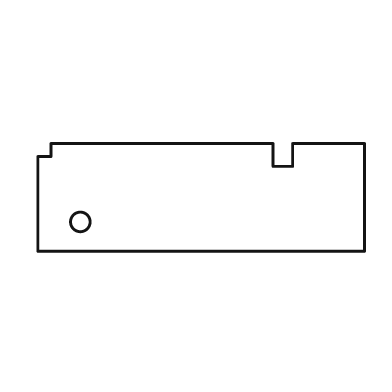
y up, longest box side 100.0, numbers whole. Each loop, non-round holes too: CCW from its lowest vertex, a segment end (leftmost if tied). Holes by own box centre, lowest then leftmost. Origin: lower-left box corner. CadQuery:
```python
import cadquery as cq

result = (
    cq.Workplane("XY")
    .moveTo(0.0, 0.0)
    .lineTo(100.0, 0.0)
    .lineTo(100.0, 33.0)
    .lineTo(78.0, 33.0)
    .lineTo(78.0, 26.0)
    .lineTo(72.0, 26.0)
    .lineTo(72.0, 33.0)
    .lineTo(4.0, 33.0)
    .lineTo(4.0, 29.0)
    .lineTo(0.0, 29.0)
    .close()
    .moveTo(13.0, 9.0)
    .circle(3.0)
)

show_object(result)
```